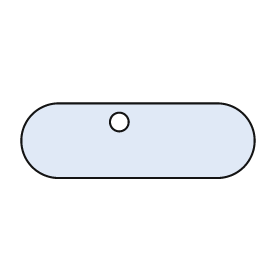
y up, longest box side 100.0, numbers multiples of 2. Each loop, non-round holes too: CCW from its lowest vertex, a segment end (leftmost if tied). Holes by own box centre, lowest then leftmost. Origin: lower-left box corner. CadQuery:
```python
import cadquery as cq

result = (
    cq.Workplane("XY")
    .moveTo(16.0, 0.0)
    .lineTo(84.0, 0.0)
    .threePointArc((100.0, 16.0), (84.0, 32.0))
    .lineTo(16.0, 32.0)
    .threePointArc((0.0, 16.0), (16.0, 0.0))
    .close()
    .moveTo(42.0, 24.0)
    .circle(4.0)
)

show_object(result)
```